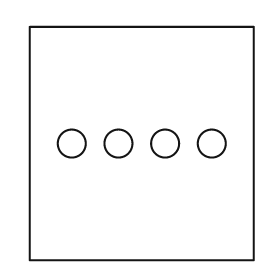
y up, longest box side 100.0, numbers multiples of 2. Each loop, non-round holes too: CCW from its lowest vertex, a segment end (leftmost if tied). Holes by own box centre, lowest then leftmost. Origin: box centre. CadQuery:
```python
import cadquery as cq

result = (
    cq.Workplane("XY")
    .moveTo(-48.0, -50.0)
    .lineTo(48.0, -50.0)
    .lineTo(48.0, 50.0)
    .lineTo(-48.0, 50.0)
    .close()
    .moveTo(-30.0, 0.0)
    .circle(6.0)
    .moveTo(-10.0, 0.0)
    .circle(6.0)
    .moveTo(10.0, 0.0)
    .circle(6.0)
    .moveTo(30.0, 0.0)
    .circle(6.0)
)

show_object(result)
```